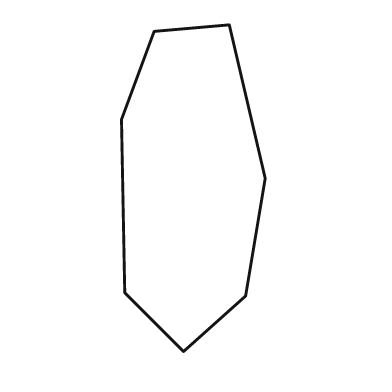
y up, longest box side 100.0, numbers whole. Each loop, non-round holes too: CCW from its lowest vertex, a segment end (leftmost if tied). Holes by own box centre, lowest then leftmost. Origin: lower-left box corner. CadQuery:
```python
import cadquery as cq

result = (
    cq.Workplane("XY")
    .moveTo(19.0, 0.0)
    .lineTo(38.0, 17.0)
    .lineTo(44.0, 53.0)
    .lineTo(33.0, 100.0)
    .lineTo(10.0, 98.0)
    .lineTo(0.0, 71.0)
    .lineTo(1.0, 18.0)
    .close()
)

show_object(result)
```